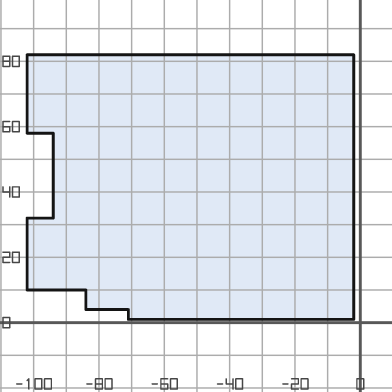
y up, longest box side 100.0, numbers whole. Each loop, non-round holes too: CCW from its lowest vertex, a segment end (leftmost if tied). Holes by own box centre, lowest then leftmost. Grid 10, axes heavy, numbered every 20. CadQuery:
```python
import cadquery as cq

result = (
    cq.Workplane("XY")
    .moveTo(-71.0, 1.0)
    .lineTo(-2.0, 1.0)
    .lineTo(-2.0, 82.0)
    .lineTo(-102.0, 82.0)
    .lineTo(-102.0, 58.0)
    .lineTo(-94.0, 58.0)
    .lineTo(-94.0, 32.0)
    .lineTo(-102.0, 32.0)
    .lineTo(-102.0, 10.0)
    .lineTo(-84.0, 10.0)
    .lineTo(-84.0, 4.0)
    .lineTo(-71.0, 4.0)
    .close()
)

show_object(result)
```